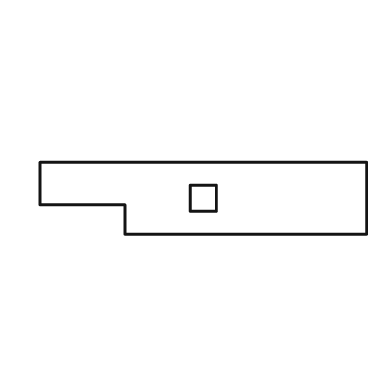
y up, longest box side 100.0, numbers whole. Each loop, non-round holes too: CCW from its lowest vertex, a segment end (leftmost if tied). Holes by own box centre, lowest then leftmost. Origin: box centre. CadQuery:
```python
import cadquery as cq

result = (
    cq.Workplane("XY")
    .moveTo(-24.0, -11.0)
    .lineTo(50.0, -11.0)
    .lineTo(50.0, 11.0)
    .lineTo(-50.0, 11.0)
    .lineTo(-50.0, -2.0)
    .lineTo(-24.0, -2.0)
    .close()
    .moveTo(-4.0, -4.0)
    .lineTo(4.0, -4.0)
    .lineTo(4.0, 4.0)
    .lineTo(-4.0, 4.0)
    .close()
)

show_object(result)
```